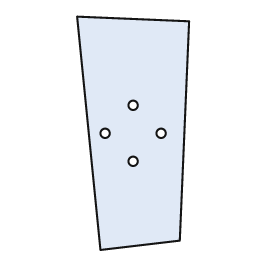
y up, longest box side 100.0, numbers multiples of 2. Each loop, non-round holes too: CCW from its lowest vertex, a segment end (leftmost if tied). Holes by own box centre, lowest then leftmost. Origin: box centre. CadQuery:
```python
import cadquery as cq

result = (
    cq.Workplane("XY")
    .moveTo(-14.0, -50.0)
    .lineTo(20.0, -46.0)
    .lineTo(24.0, 48.0)
    .lineTo(-24.0, 50.0)
    .close()
    .moveTo(0.0, -12.0)
    .circle(2.0)
    .moveTo(-12.0, 0.0)
    .circle(2.0)
    .moveTo(12.0, 0.0)
    .circle(2.0)
    .moveTo(0.0, 12.0)
    .circle(2.0)
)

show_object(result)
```